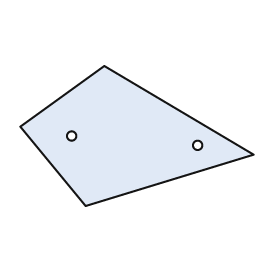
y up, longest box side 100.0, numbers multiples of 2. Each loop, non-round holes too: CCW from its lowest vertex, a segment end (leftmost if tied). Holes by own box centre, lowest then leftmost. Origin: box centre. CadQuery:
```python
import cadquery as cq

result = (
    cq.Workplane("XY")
    .moveTo(-22.0, -30.0)
    .lineTo(50.0, -8.0)
    .lineTo(-14.0, 30.0)
    .lineTo(-50.0, 4.0)
    .close()
    .moveTo(26.0, -4.0)
    .circle(2.0)
    .moveTo(-28.0, 0.0)
    .circle(2.0)
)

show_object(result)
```